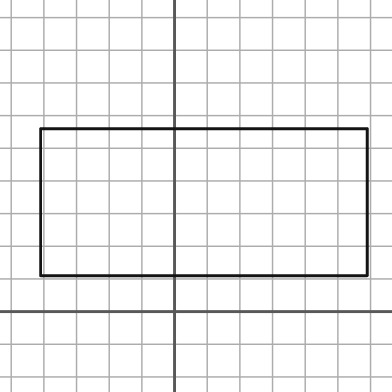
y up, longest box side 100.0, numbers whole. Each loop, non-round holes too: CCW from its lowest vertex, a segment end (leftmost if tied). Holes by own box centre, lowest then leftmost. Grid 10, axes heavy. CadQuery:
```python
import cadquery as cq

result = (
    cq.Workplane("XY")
    .moveTo(-41.0, 11.0)
    .lineTo(59.0, 11.0)
    .lineTo(59.0, 56.0)
    .lineTo(-41.0, 56.0)
    .close()
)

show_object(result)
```